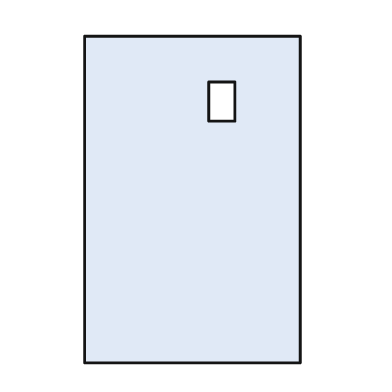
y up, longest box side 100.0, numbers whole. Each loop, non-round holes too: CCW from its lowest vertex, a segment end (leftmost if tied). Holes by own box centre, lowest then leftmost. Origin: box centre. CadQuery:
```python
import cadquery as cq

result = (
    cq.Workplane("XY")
    .moveTo(-33.0, -50.0)
    .lineTo(33.0, -50.0)
    .lineTo(33.0, 50.0)
    .lineTo(-33.0, 50.0)
    .close()
    .moveTo(5.0, 24.0)
    .lineTo(13.0, 24.0)
    .lineTo(13.0, 36.0)
    .lineTo(5.0, 36.0)
    .close()
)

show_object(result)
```